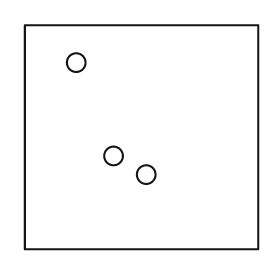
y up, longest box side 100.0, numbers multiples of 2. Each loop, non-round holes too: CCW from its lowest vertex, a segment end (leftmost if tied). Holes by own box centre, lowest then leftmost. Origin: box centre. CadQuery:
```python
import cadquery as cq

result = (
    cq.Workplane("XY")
    .moveTo(-50.0, -48.0)
    .lineTo(50.0, -48.0)
    .lineTo(50.0, 48.0)
    .lineTo(-50.0, 48.0)
    .close()
    .moveTo(2.0, -16.0)
    .circle(4.0)
    .moveTo(-12.0, -8.0)
    .circle(4.0)
    .moveTo(-28.0, 32.0)
    .circle(4.0)
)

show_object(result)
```